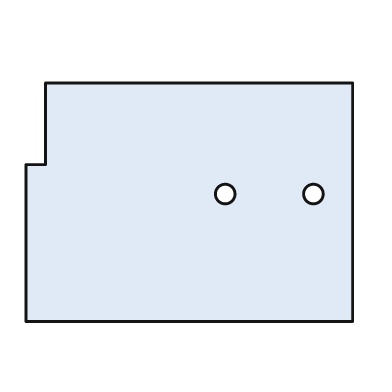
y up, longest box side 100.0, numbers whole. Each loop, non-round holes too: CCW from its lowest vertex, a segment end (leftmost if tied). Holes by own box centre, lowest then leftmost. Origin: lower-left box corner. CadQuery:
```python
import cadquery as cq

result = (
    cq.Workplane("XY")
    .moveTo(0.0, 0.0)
    .lineTo(100.0, 0.0)
    .lineTo(100.0, 73.0)
    .lineTo(6.0, 73.0)
    .lineTo(6.0, 48.0)
    .lineTo(0.0, 48.0)
    .close()
    .moveTo(61.0, 39.0)
    .circle(3.0)
    .moveTo(88.0, 39.0)
    .circle(3.0)
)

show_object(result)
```